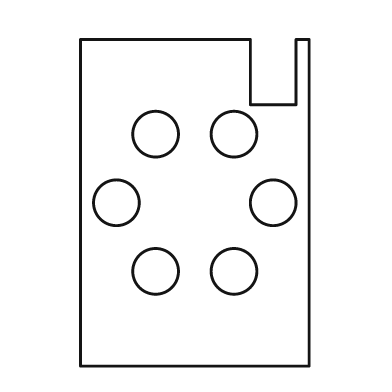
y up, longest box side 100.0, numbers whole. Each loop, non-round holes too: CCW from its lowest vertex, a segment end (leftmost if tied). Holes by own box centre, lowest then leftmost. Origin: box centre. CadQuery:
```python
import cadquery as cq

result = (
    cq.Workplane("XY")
    .moveTo(-35.0, -50.0)
    .lineTo(35.0, -50.0)
    .lineTo(35.0, 50.0)
    .lineTo(31.0, 50.0)
    .lineTo(31.0, 30.0)
    .lineTo(17.0, 30.0)
    .lineTo(17.0, 50.0)
    .lineTo(-35.0, 50.0)
    .close()
    .moveTo(-12.0, -21.0)
    .circle(7.0)
    .moveTo(12.0, -21.0)
    .circle(7.0)
    .moveTo(-24.0, 0.0)
    .circle(7.0)
    .moveTo(24.0, 0.0)
    .circle(7.0)
    .moveTo(-12.0, 21.0)
    .circle(7.0)
    .moveTo(12.0, 21.0)
    .circle(7.0)
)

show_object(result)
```